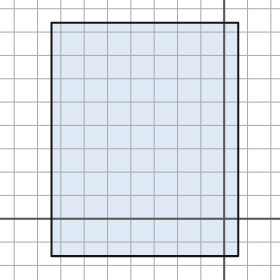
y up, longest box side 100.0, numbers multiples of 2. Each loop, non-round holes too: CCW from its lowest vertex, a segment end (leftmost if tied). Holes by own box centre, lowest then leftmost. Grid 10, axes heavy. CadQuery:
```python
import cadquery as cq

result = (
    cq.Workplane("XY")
    .moveTo(-74.0, -16.0)
    .lineTo(6.0, -16.0)
    .lineTo(6.0, 84.0)
    .lineTo(-74.0, 84.0)
    .close()
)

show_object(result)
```